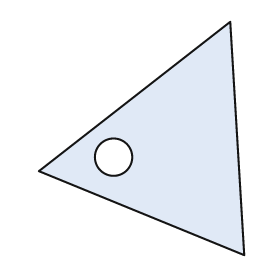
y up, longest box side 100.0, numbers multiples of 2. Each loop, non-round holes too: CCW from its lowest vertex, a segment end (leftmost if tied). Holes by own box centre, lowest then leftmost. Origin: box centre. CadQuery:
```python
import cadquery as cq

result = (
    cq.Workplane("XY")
    .moveTo(44.0, -50.0)
    .lineTo(38.0, 50.0)
    .lineTo(-44.0, -14.0)
    .close()
    .moveTo(-12.0, -8.0)
    .circle(8.0)
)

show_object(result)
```